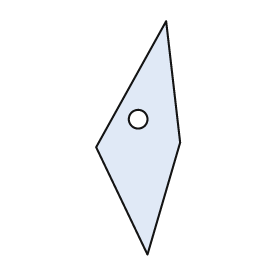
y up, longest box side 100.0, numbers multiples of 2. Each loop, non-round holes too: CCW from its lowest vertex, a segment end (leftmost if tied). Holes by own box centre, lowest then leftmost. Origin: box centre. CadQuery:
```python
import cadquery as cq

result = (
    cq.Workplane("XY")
    .moveTo(4.0, -50.0)
    .lineTo(18.0, -2.0)
    .lineTo(12.0, 50.0)
    .lineTo(-18.0, -4.0)
    .close()
    .moveTo(0.0, 8.0)
    .circle(4.0)
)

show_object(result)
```